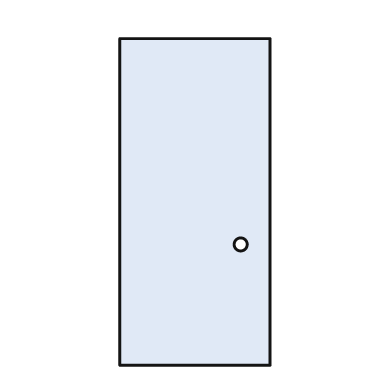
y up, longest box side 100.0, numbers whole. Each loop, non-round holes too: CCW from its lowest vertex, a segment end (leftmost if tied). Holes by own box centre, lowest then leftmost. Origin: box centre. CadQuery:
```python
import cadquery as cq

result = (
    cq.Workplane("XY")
    .moveTo(-23.0, -50.0)
    .lineTo(23.0, -50.0)
    .lineTo(23.0, 50.0)
    .lineTo(-23.0, 50.0)
    .close()
    .moveTo(14.0, -13.0)
    .circle(2.0)
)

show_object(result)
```